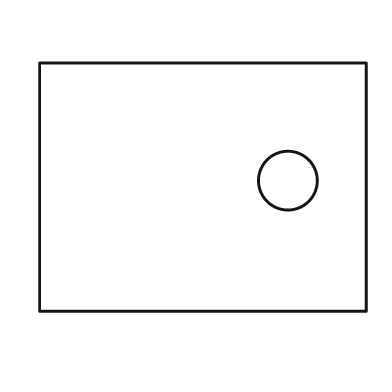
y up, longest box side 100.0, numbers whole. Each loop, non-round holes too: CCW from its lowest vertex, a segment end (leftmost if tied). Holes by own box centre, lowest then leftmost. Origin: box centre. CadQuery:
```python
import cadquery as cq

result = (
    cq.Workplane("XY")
    .moveTo(-50.0, -38.0)
    .lineTo(50.0, -38.0)
    .lineTo(50.0, 38.0)
    .lineTo(-50.0, 38.0)
    .close()
    .moveTo(26.0, 2.0)
    .circle(9.0)
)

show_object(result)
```